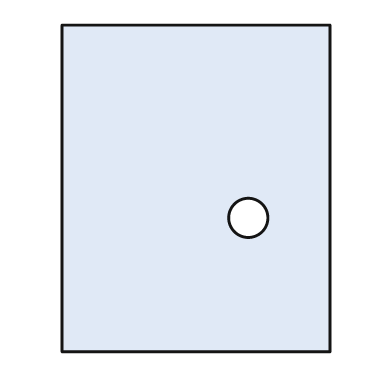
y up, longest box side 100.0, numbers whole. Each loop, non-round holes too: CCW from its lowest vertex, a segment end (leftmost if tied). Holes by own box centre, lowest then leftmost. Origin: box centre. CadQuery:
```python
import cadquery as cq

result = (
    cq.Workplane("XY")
    .moveTo(-41.0, -50.0)
    .lineTo(41.0, -50.0)
    .lineTo(41.0, 50.0)
    .lineTo(-41.0, 50.0)
    .close()
    .moveTo(16.0, -9.0)
    .circle(6.0)
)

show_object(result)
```